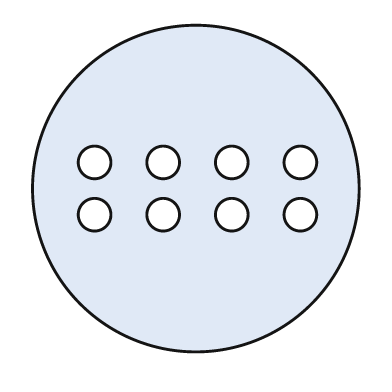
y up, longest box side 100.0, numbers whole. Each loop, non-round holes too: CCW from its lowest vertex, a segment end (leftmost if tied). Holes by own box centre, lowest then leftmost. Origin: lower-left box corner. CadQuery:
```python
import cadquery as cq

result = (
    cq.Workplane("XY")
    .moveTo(50.0, 50.0)
    .circle(50.0)
    .moveTo(19.0, 42.0)
    .circle(5.0)
    .moveTo(40.0, 42.0)
    .circle(5.0)
    .moveTo(61.0, 42.0)
    .circle(5.0)
    .moveTo(82.0, 42.0)
    .circle(5.0)
    .moveTo(19.0, 58.0)
    .circle(5.0)
    .moveTo(40.0, 58.0)
    .circle(5.0)
    .moveTo(61.0, 58.0)
    .circle(5.0)
    .moveTo(82.0, 58.0)
    .circle(5.0)
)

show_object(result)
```